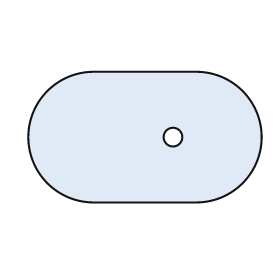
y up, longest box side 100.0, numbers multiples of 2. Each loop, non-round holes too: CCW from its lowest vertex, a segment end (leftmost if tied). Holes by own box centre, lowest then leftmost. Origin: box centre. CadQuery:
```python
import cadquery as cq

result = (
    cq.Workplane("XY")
    .moveTo(-22.0, -28.0)
    .lineTo(22.0, -28.0)
    .threePointArc((50.0, 0.0), (22.0, 28.0))
    .lineTo(-22.0, 28.0)
    .threePointArc((-50.0, 0.0), (-22.0, -28.0))
    .close()
    .moveTo(12.0, 0.0)
    .circle(4.0)
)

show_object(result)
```